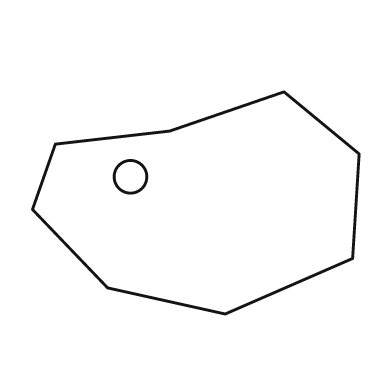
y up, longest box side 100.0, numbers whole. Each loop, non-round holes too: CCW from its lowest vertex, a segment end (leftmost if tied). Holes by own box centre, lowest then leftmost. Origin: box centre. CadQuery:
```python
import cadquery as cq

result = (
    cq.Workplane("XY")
    .moveTo(9.0, -34.0)
    .lineTo(48.0, -17.0)
    .lineTo(50.0, 15.0)
    .lineTo(27.0, 34.0)
    .lineTo(-8.0, 22.0)
    .lineTo(-43.0, 18.0)
    .lineTo(-50.0, -2.0)
    .lineTo(-27.0, -26.0)
    .close()
    .moveTo(-20.0, 8.0)
    .circle(5.0)
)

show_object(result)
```